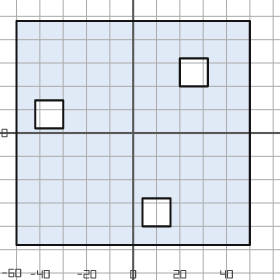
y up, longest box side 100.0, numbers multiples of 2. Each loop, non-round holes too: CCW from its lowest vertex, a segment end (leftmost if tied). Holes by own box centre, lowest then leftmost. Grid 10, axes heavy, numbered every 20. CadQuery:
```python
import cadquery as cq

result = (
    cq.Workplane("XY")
    .moveTo(-50.0, -48.0)
    .lineTo(50.0, -48.0)
    .lineTo(50.0, 48.0)
    .lineTo(-50.0, 48.0)
    .close()
    .moveTo(4.0, -40.0)
    .lineTo(16.0, -40.0)
    .lineTo(16.0, -28.0)
    .lineTo(4.0, -28.0)
    .close()
    .moveTo(-42.0, 2.0)
    .lineTo(-30.0, 2.0)
    .lineTo(-30.0, 14.0)
    .lineTo(-42.0, 14.0)
    .close()
    .moveTo(20.0, 20.0)
    .lineTo(32.0, 20.0)
    .lineTo(32.0, 32.0)
    .lineTo(20.0, 32.0)
    .close()
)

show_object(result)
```